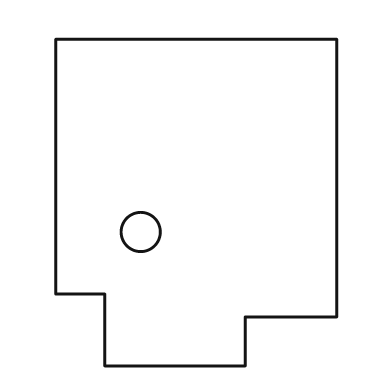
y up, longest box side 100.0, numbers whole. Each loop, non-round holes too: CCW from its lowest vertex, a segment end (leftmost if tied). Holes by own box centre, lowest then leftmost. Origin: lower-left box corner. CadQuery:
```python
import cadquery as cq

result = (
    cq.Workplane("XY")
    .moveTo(15.0, 0.0)
    .lineTo(58.0, 0.0)
    .lineTo(58.0, 15.0)
    .lineTo(86.0, 15.0)
    .lineTo(86.0, 100.0)
    .lineTo(0.0, 100.0)
    .lineTo(0.0, 22.0)
    .lineTo(15.0, 22.0)
    .close()
    .moveTo(26.0, 41.0)
    .circle(6.0)
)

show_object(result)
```